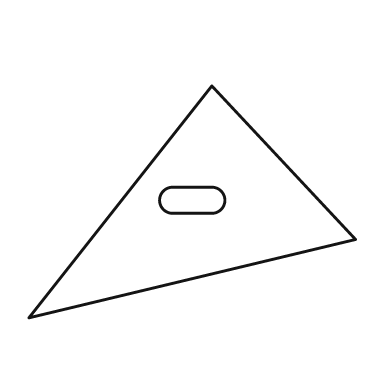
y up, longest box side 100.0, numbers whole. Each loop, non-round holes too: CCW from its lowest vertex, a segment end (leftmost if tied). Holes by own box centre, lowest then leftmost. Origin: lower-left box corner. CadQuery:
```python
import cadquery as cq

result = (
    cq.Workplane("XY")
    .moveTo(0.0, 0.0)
    .lineTo(100.0, 24.0)
    .lineTo(56.0, 71.0)
    .close()
    .moveTo(44.0, 32.0)
    .lineTo(56.0, 32.0)
    .threePointArc((60.0, 36.0), (56.0, 40.0))
    .lineTo(44.0, 40.0)
    .threePointArc((40.0, 36.0), (44.0, 32.0))
    .close()
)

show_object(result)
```